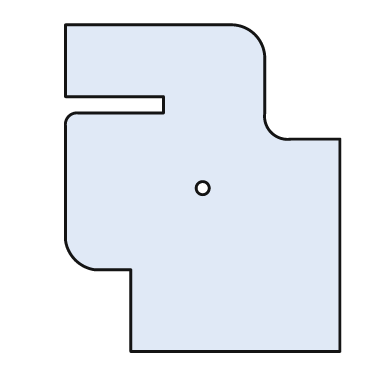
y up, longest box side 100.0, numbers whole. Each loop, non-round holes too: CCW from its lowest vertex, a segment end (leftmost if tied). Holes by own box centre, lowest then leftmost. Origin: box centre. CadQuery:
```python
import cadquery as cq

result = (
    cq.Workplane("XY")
    .moveTo(-22.0, -50.0)
    .lineTo(42.0, -50.0)
    .lineTo(42.0, 15.0)
    .lineTo(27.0, 15.0)
    .threePointArc((21.0, 17.0), (19.0, 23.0))
    .lineTo(19.0, 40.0)
    .threePointArc((16.0, 47.0), (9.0, 50.0))
    .lineTo(-42.0, 50.0)
    .lineTo(-42.0, 28.0)
    .lineTo(-12.0, 28.0)
    .lineTo(-12.0, 23.0)
    .lineTo(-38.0, 23.0)
    .threePointArc((-41.0, 22.0), (-42.0, 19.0))
    .lineTo(-42.0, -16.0)
    .threePointArc((-39.0, -22.0), (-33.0, -25.0))
    .lineTo(-22.0, -25.0)
    .close()
    .moveTo(0.0, 0.0)
    .circle(2.0)
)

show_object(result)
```